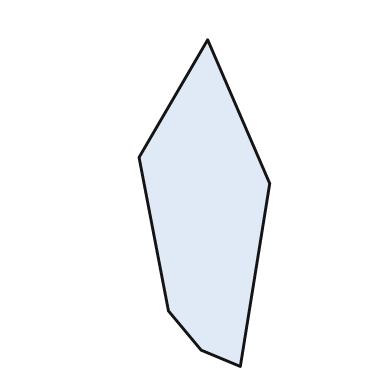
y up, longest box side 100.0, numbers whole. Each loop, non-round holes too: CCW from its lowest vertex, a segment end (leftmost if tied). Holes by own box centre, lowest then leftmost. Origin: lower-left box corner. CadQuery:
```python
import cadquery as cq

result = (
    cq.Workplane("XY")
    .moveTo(31.0, 0.0)
    .lineTo(40.0, 56.0)
    .lineTo(21.0, 100.0)
    .lineTo(0.0, 64.0)
    .lineTo(9.0, 17.0)
    .lineTo(19.0, 5.0)
    .close()
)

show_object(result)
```